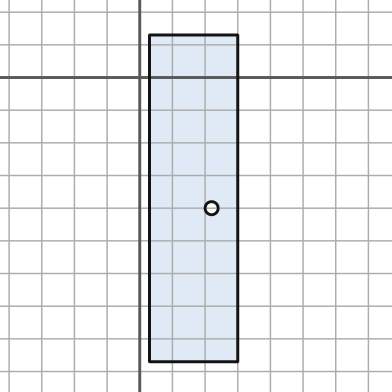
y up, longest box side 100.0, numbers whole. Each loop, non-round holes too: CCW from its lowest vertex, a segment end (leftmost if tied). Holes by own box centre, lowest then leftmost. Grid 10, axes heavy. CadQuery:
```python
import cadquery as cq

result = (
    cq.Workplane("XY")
    .moveTo(3.0, -87.0)
    .lineTo(30.0, -87.0)
    .lineTo(30.0, 13.0)
    .lineTo(3.0, 13.0)
    .close()
    .moveTo(22.0, -40.0)
    .circle(2.0)
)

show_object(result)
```